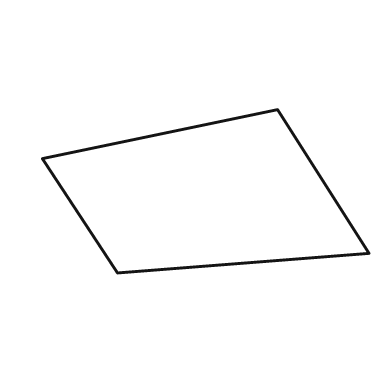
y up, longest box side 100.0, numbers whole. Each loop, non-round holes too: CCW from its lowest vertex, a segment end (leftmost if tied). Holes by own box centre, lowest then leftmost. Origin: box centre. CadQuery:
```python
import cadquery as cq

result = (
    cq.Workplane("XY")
    .moveTo(-27.0, -25.0)
    .lineTo(50.0, -19.0)
    .lineTo(22.0, 25.0)
    .lineTo(-50.0, 10.0)
    .close()
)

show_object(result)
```